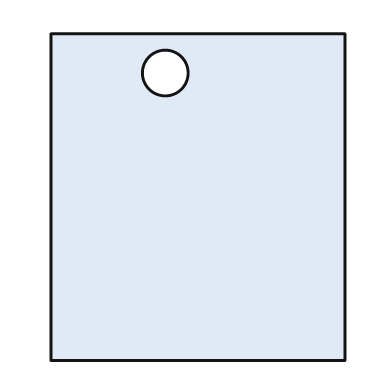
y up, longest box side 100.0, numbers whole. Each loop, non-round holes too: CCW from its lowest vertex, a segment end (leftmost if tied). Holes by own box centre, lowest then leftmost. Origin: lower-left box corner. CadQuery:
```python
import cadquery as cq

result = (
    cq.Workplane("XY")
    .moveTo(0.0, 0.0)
    .lineTo(90.0, 0.0)
    .lineTo(90.0, 100.0)
    .lineTo(0.0, 100.0)
    .close()
    .moveTo(35.0, 88.0)
    .circle(7.0)
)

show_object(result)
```